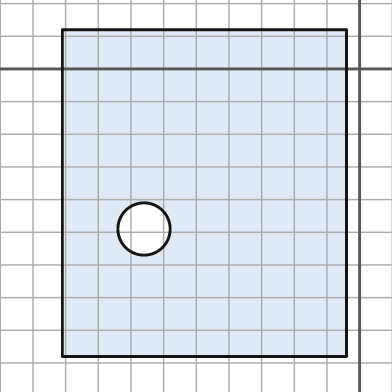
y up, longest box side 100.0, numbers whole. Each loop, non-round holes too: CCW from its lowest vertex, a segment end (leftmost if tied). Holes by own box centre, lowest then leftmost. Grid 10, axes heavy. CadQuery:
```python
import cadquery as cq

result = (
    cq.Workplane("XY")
    .moveTo(-91.0, -88.0)
    .lineTo(-4.0, -88.0)
    .lineTo(-4.0, 12.0)
    .lineTo(-91.0, 12.0)
    .close()
    .moveTo(-66.0, -49.0)
    .circle(8.0)
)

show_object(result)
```